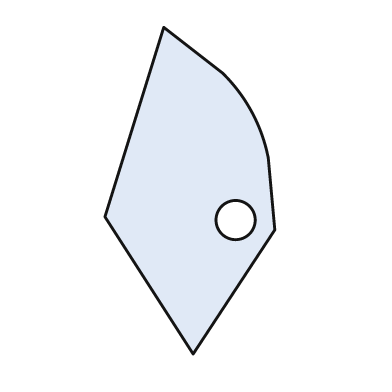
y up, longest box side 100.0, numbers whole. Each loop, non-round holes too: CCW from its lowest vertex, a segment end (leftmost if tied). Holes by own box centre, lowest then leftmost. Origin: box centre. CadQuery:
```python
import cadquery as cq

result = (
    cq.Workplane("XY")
    .moveTo(1.0, -50.0)
    .lineTo(26.0, -12.0)
    .lineTo(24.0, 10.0)
    .threePointArc((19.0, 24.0), (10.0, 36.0))
    .lineTo(-8.0, 50.0)
    .lineTo(-26.0, -8.0)
    .close()
    .moveTo(14.0, -9.0)
    .circle(6.0)
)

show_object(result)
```